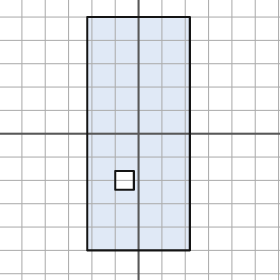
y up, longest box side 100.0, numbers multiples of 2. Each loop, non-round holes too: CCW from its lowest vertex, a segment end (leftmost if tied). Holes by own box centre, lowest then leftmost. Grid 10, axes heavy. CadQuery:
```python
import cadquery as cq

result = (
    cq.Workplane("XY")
    .moveTo(-22.0, -50.0)
    .lineTo(22.0, -50.0)
    .lineTo(22.0, 50.0)
    .lineTo(-22.0, 50.0)
    .close()
    .moveTo(-10.0, -24.0)
    .lineTo(-2.0, -24.0)
    .lineTo(-2.0, -16.0)
    .lineTo(-10.0, -16.0)
    .close()
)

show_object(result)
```